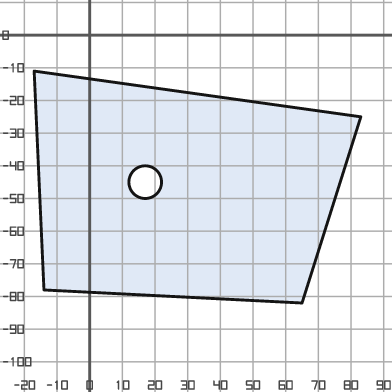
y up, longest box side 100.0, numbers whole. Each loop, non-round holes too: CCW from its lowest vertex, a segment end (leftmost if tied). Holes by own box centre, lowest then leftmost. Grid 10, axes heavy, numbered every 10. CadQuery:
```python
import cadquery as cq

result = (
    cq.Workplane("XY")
    .moveTo(65.0, -82.0)
    .lineTo(83.0, -25.0)
    .lineTo(-17.0, -11.0)
    .lineTo(-14.0, -78.0)
    .close()
    .moveTo(17.0, -45.0)
    .circle(5.0)
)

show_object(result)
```